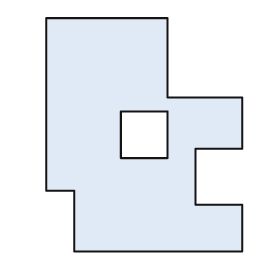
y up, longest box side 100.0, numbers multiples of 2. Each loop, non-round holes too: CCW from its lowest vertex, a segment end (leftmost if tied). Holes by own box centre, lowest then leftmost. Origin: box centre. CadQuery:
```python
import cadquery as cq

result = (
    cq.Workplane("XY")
    .moveTo(-30.0, -50.0)
    .lineTo(42.0, -50.0)
    .lineTo(42.0, -30.0)
    .lineTo(22.0, -30.0)
    .lineTo(22.0, -6.0)
    .lineTo(42.0, -6.0)
    .lineTo(42.0, 16.0)
    .lineTo(10.0, 16.0)
    .lineTo(10.0, 50.0)
    .lineTo(-42.0, 50.0)
    .lineTo(-42.0, -24.0)
    .lineTo(-30.0, -24.0)
    .close()
    .moveTo(-10.0, -10.0)
    .lineTo(10.0, -10.0)
    .lineTo(10.0, 10.0)
    .lineTo(-10.0, 10.0)
    .close()
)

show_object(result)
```